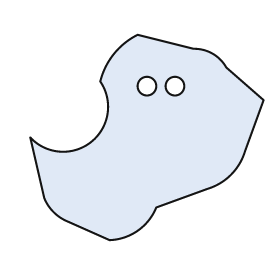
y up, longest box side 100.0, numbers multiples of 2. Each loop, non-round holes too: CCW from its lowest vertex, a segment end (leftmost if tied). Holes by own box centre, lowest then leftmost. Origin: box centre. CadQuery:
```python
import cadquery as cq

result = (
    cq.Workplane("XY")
    .moveTo(-16.0, -44.0)
    .threePointArc((-4.0, -40.0), (4.0, -30.0))
    .lineTo(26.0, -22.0)
    .threePointArc((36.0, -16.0), (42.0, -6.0))
    .lineTo(50.0, 16.0)
    .lineTo(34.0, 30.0)
    .threePointArc((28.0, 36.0), (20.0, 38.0))
    .lineTo(-4.0, 44.0)
    .threePointArc((-14.0, 36.0), (-20.0, 24.0))
    .threePointArc((-24.0, -2.0), (-50.0, 0.0))
    .lineTo(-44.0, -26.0)
    .threePointArc((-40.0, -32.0), (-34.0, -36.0))
    .close()
    .moveTo(0.0, 22.0)
    .circle(4.0)
    .moveTo(12.0, 22.0)
    .circle(4.0)
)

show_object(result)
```